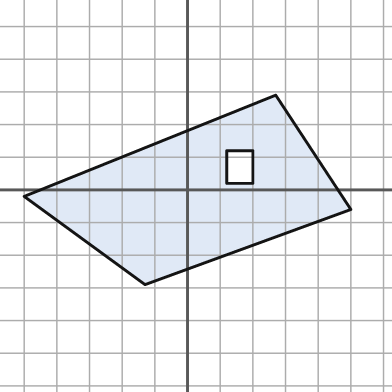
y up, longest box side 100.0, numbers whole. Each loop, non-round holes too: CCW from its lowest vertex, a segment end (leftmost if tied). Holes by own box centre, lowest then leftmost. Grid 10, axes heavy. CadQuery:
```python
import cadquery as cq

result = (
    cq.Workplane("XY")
    .moveTo(-13.0, -29.0)
    .lineTo(50.0, -6.0)
    .lineTo(27.0, 29.0)
    .lineTo(-50.0, -2.0)
    .close()
    .moveTo(12.0, 2.0)
    .lineTo(20.0, 2.0)
    .lineTo(20.0, 12.0)
    .lineTo(12.0, 12.0)
    .close()
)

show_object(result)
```